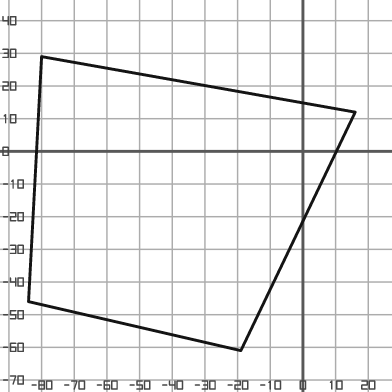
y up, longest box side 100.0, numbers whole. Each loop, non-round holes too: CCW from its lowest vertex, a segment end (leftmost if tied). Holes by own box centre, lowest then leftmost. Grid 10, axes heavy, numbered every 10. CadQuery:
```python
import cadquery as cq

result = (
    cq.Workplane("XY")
    .moveTo(-19.0, -61.0)
    .lineTo(16.0, 12.0)
    .lineTo(-80.0, 29.0)
    .lineTo(-84.0, -46.0)
    .close()
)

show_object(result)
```